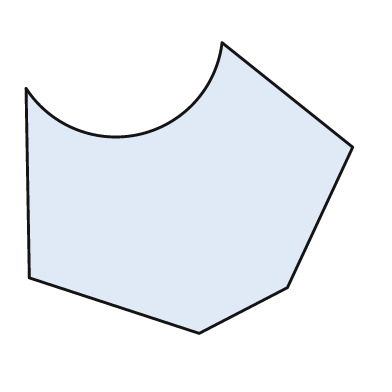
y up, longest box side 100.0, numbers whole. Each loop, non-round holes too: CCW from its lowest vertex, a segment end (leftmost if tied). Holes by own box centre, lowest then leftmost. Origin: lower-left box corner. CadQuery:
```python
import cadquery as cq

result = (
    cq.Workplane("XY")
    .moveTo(53.0, 0.0)
    .lineTo(80.0, 14.0)
    .lineTo(100.0, 57.0)
    .lineTo(60.0, 89.0)
    .threePointArc((35.0, 61.0), (0.0, 75.0))
    .lineTo(1.0, 17.0)
    .close()
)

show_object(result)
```